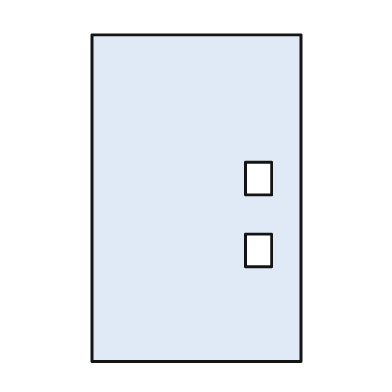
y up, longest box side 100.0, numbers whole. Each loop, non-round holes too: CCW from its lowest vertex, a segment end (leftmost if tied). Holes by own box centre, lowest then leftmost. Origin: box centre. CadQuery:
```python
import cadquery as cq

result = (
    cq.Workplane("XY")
    .moveTo(-32.0, -50.0)
    .lineTo(32.0, -50.0)
    .lineTo(32.0, 50.0)
    .lineTo(-32.0, 50.0)
    .close()
    .moveTo(15.0, -21.0)
    .lineTo(23.0, -21.0)
    .lineTo(23.0, -11.0)
    .lineTo(15.0, -11.0)
    .close()
    .moveTo(15.0, 1.0)
    .lineTo(23.0, 1.0)
    .lineTo(23.0, 11.0)
    .lineTo(15.0, 11.0)
    .close()
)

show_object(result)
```